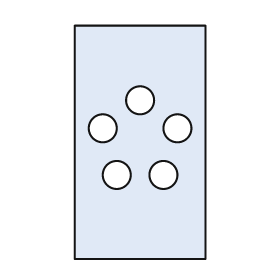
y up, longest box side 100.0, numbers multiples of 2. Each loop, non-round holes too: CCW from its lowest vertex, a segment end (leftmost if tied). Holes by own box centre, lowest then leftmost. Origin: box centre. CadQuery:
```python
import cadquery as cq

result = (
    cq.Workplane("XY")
    .moveTo(-28.0, -50.0)
    .lineTo(28.0, -50.0)
    .lineTo(28.0, 50.0)
    .lineTo(-28.0, 50.0)
    .close()
    .moveTo(-10.0, -14.0)
    .circle(6.0)
    .moveTo(10.0, -14.0)
    .circle(6.0)
    .moveTo(-16.0, 6.0)
    .circle(6.0)
    .moveTo(16.0, 6.0)
    .circle(6.0)
    .moveTo(0.0, 18.0)
    .circle(6.0)
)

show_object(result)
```